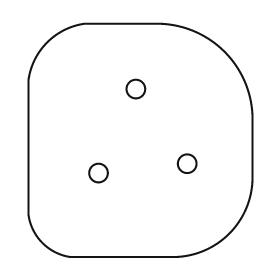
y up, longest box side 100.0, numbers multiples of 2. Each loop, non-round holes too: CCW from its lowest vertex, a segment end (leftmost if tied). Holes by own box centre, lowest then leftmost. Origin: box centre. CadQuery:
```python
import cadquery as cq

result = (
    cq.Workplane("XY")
    .moveTo(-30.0, -50.0)
    .lineTo(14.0, -50.0)
    .threePointArc((38.0, -40.0), (48.0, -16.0))
    .lineTo(48.0, 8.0)
    .threePointArc((36.0, 38.0), (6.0, 50.0))
    .lineTo(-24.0, 50.0)
    .threePointArc((-40.0, 42.0), (-48.0, 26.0))
    .lineTo(-48.0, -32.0)
    .threePointArc((-42.0, -44.0), (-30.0, -50.0))
    .close()
    .moveTo(-18.0, -14.0)
    .circle(4.0)
    .moveTo(20.0, -10.0)
    .circle(4.0)
    .moveTo(-2.0, 22.0)
    .circle(4.0)
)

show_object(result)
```